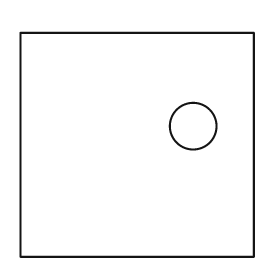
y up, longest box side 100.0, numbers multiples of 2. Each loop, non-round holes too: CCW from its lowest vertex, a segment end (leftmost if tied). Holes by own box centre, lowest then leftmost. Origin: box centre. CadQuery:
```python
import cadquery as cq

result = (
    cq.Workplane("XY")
    .moveTo(-50.0, -48.0)
    .lineTo(50.0, -48.0)
    .lineTo(50.0, 48.0)
    .lineTo(-50.0, 48.0)
    .close()
    .moveTo(24.0, 8.0)
    .circle(10.0)
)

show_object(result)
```